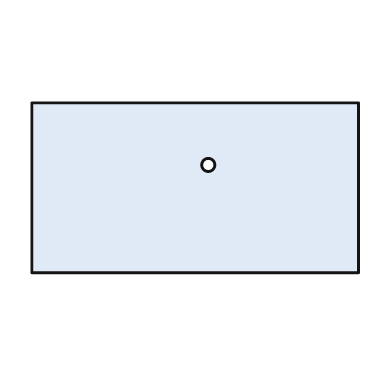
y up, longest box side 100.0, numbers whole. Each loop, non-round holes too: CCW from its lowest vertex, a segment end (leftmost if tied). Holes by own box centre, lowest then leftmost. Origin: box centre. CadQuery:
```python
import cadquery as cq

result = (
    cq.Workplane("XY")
    .moveTo(-50.0, -26.0)
    .lineTo(50.0, -26.0)
    .lineTo(50.0, 26.0)
    .lineTo(-50.0, 26.0)
    .close()
    .moveTo(4.0, 7.0)
    .circle(2.0)
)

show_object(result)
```